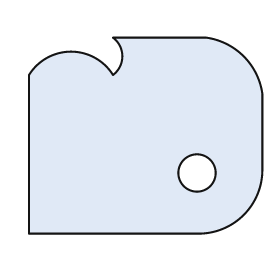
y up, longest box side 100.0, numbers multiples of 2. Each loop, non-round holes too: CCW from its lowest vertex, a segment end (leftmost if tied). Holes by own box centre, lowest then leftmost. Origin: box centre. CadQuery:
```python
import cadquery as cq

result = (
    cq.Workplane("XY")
    .moveTo(-50.0, -42.0)
    .lineTo(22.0, -42.0)
    .threePointArc((42.0, -34.0), (50.0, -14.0))
    .lineTo(50.0, 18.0)
    .threePointArc((42.0, 34.0), (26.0, 42.0))
    .lineTo(-14.0, 42.0)
    .threePointArc((-10.0, 34.0), (-14.0, 26.0))
    .threePointArc((-32.0, 36.0), (-50.0, 26.0))
    .close()
    .moveTo(22.0, -16.0)
    .circle(8.0)
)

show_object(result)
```